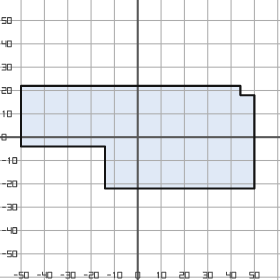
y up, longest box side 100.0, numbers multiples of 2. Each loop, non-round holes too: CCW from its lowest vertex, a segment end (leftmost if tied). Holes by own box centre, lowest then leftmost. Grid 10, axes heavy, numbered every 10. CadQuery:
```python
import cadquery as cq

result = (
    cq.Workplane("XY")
    .moveTo(-14.0, -22.0)
    .lineTo(50.0, -22.0)
    .lineTo(50.0, 18.0)
    .lineTo(44.0, 18.0)
    .lineTo(44.0, 22.0)
    .lineTo(-50.0, 22.0)
    .lineTo(-50.0, -4.0)
    .lineTo(-14.0, -4.0)
    .close()
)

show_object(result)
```